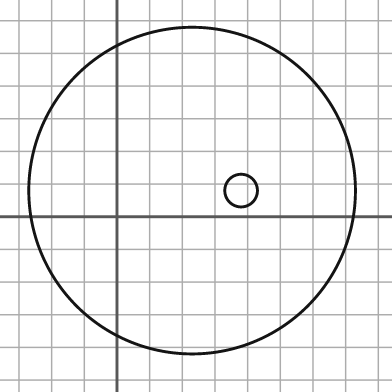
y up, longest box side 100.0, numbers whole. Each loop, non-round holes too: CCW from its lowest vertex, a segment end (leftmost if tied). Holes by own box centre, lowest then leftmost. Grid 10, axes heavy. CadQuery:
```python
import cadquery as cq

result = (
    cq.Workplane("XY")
    .moveTo(23.0, 8.0)
    .circle(50.0)
    .moveTo(38.0, 8.0)
    .circle(5.0)
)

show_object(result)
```